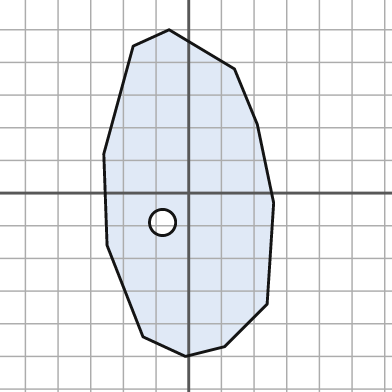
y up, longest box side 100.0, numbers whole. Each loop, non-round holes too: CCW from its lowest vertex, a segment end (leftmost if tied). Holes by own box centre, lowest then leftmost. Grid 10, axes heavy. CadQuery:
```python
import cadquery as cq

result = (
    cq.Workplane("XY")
    .moveTo(-1.0, -50.0)
    .lineTo(11.0, -47.0)
    .lineTo(24.0, -34.0)
    .lineTo(26.0, -3.0)
    .lineTo(21.0, 21.0)
    .lineTo(14.0, 38.0)
    .lineTo(-6.0, 50.0)
    .lineTo(-17.0, 45.0)
    .lineTo(-26.0, 12.0)
    .lineTo(-25.0, -16.0)
    .lineTo(-14.0, -44.0)
    .close()
    .moveTo(-8.0, -9.0)
    .circle(4.0)
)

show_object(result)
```